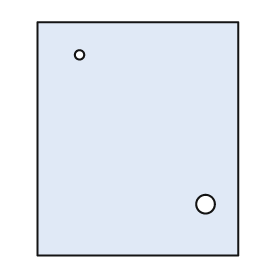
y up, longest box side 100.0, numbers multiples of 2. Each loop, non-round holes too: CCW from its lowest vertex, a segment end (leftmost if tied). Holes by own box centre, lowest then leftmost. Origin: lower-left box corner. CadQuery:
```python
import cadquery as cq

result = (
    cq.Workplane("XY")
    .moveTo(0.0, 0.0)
    .lineTo(86.0, 0.0)
    .lineTo(86.0, 100.0)
    .lineTo(0.0, 100.0)
    .close()
    .moveTo(72.0, 22.0)
    .circle(4.0)
    .moveTo(18.0, 86.0)
    .circle(2.0)
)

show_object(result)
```